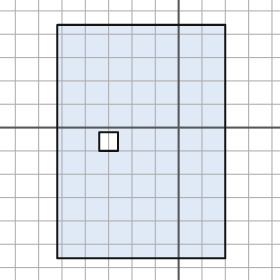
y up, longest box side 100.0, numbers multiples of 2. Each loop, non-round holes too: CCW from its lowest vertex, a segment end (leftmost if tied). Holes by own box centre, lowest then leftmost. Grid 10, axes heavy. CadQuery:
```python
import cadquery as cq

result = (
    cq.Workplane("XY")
    .moveTo(-52.0, -56.0)
    .lineTo(20.0, -56.0)
    .lineTo(20.0, 44.0)
    .lineTo(-52.0, 44.0)
    .close()
    .moveTo(-34.0, -10.0)
    .lineTo(-26.0, -10.0)
    .lineTo(-26.0, -2.0)
    .lineTo(-34.0, -2.0)
    .close()
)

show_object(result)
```